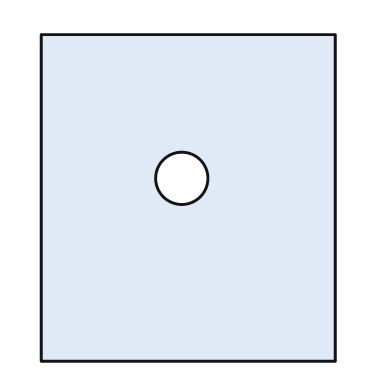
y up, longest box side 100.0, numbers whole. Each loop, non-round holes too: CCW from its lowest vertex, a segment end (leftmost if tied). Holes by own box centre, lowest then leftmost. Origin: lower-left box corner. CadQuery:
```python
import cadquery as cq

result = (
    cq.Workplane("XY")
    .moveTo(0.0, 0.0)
    .lineTo(90.0, 0.0)
    .lineTo(90.0, 100.0)
    .lineTo(0.0, 100.0)
    .close()
    .moveTo(43.0, 56.0)
    .circle(8.0)
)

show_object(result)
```